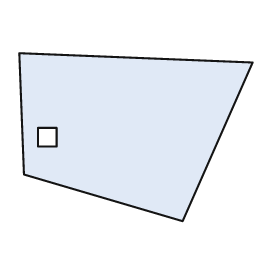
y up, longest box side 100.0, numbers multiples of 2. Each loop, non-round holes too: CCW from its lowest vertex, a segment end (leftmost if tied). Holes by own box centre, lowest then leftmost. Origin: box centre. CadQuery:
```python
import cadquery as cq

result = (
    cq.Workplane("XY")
    .moveTo(20.0, -36.0)
    .lineTo(50.0, 32.0)
    .lineTo(-50.0, 36.0)
    .lineTo(-48.0, -16.0)
    .close()
    .moveTo(-42.0, -4.0)
    .lineTo(-34.0, -4.0)
    .lineTo(-34.0, 4.0)
    .lineTo(-42.0, 4.0)
    .close()
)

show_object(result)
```